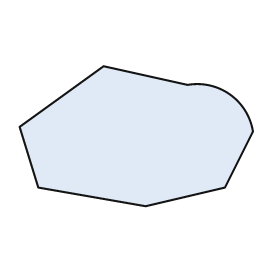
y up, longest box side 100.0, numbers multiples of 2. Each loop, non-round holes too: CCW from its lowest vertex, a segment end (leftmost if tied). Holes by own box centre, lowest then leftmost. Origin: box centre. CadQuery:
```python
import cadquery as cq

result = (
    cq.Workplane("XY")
    .moveTo(4.0, -30.0)
    .lineTo(38.0, -22.0)
    .lineTo(50.0, 2.0)
    .threePointArc((40.0, 18.0), (22.0, 22.0))
    .lineTo(-14.0, 30.0)
    .lineTo(-50.0, 4.0)
    .lineTo(-42.0, -22.0)
    .close()
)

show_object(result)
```